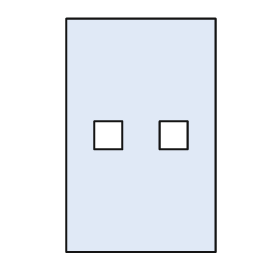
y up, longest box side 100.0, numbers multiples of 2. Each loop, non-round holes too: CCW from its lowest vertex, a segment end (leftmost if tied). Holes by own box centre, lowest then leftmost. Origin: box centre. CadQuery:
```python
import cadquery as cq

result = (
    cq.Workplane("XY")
    .moveTo(-32.0, -50.0)
    .lineTo(32.0, -50.0)
    .lineTo(32.0, 50.0)
    .lineTo(-32.0, 50.0)
    .close()
    .moveTo(-20.0, -6.0)
    .lineTo(-8.0, -6.0)
    .lineTo(-8.0, 6.0)
    .lineTo(-20.0, 6.0)
    .close()
    .moveTo(8.0, -6.0)
    .lineTo(20.0, -6.0)
    .lineTo(20.0, 6.0)
    .lineTo(8.0, 6.0)
    .close()
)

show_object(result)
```